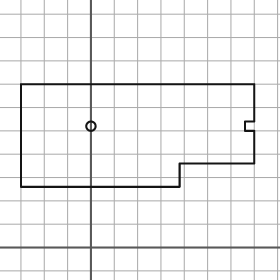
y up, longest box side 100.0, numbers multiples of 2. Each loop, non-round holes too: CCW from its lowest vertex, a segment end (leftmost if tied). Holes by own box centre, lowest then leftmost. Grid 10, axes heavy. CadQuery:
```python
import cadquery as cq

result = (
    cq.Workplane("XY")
    .moveTo(-30.0, 26.0)
    .lineTo(38.0, 26.0)
    .lineTo(38.0, 36.0)
    .lineTo(70.0, 36.0)
    .lineTo(70.0, 50.0)
    .lineTo(66.0, 50.0)
    .lineTo(66.0, 54.0)
    .lineTo(70.0, 54.0)
    .lineTo(70.0, 70.0)
    .lineTo(-30.0, 70.0)
    .close()
    .moveTo(0.0, 52.0)
    .circle(2.0)
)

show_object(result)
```